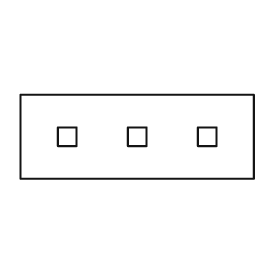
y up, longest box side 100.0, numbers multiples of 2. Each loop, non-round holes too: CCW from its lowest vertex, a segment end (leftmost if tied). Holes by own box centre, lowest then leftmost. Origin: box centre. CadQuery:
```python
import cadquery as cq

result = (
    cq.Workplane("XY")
    .moveTo(-50.0, -18.0)
    .lineTo(50.0, -18.0)
    .lineTo(50.0, 18.0)
    .lineTo(-50.0, 18.0)
    .close()
    .moveTo(-34.0, -4.0)
    .lineTo(-26.0, -4.0)
    .lineTo(-26.0, 4.0)
    .lineTo(-34.0, 4.0)
    .close()
    .moveTo(-4.0, -4.0)
    .lineTo(4.0, -4.0)
    .lineTo(4.0, 4.0)
    .lineTo(-4.0, 4.0)
    .close()
    .moveTo(26.0, -4.0)
    .lineTo(34.0, -4.0)
    .lineTo(34.0, 4.0)
    .lineTo(26.0, 4.0)
    .close()
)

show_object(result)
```